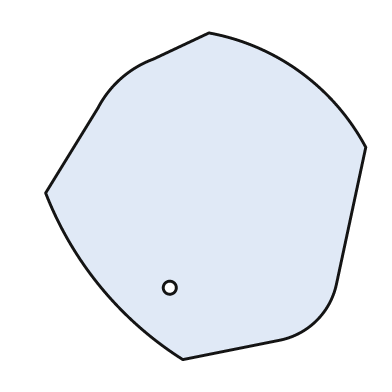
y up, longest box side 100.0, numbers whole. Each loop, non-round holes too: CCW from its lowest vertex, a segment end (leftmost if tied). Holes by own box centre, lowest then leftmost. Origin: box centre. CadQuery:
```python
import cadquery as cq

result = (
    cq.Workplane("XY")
    .moveTo(-7.0, -50.0)
    .lineTo(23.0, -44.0)
    .threePointArc((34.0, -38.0), (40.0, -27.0))
    .lineTo(49.0, 15.0)
    .threePointArc((29.0, 38.0), (1.0, 50.0))
    .lineTo(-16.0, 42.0)
    .threePointArc((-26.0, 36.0), (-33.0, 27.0))
    .lineTo(-49.0, 1.0)
    .threePointArc((-32.0, -28.0), (-7.0, -50.0))
    .close()
    .moveTo(-11.0, -28.0)
    .circle(2.0)
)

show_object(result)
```